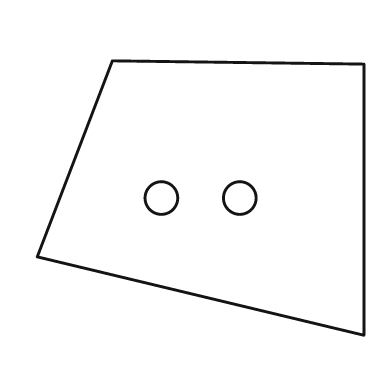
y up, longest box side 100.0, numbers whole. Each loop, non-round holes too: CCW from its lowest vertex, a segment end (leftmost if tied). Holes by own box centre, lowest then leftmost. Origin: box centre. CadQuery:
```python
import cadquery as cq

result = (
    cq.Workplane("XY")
    .moveTo(50.0, -42.0)
    .lineTo(50.0, 41.0)
    .lineTo(-27.0, 42.0)
    .lineTo(-50.0, -18.0)
    .close()
    .moveTo(-12.0, 0.0)
    .circle(5.0)
    .moveTo(12.0, 0.0)
    .circle(5.0)
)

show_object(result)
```